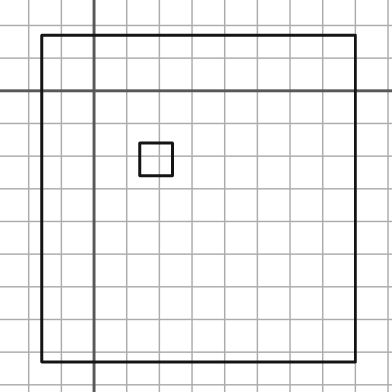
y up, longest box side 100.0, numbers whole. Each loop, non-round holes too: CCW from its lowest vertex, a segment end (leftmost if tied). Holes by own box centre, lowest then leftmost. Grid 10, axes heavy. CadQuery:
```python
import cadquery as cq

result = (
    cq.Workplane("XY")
    .moveTo(-16.0, -83.0)
    .lineTo(80.0, -83.0)
    .lineTo(80.0, 17.0)
    .lineTo(-16.0, 17.0)
    .close()
    .moveTo(14.0, -26.0)
    .lineTo(24.0, -26.0)
    .lineTo(24.0, -16.0)
    .lineTo(14.0, -16.0)
    .close()
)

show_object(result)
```